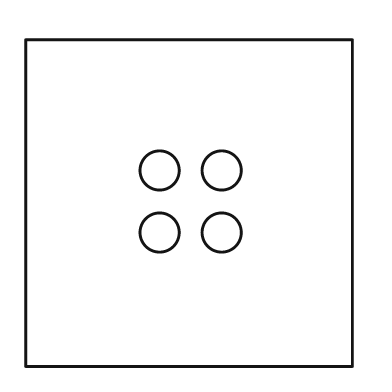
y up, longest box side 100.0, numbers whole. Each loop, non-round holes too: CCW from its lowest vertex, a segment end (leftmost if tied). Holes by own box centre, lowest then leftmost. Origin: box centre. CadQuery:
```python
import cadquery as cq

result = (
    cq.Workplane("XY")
    .moveTo(-50.0, -50.0)
    .lineTo(50.0, -50.0)
    .lineTo(50.0, 50.0)
    .lineTo(-50.0, 50.0)
    .close()
    .moveTo(-9.0, -9.0)
    .circle(6.0)
    .moveTo(10.0, -9.0)
    .circle(6.0)
    .moveTo(-9.0, 10.0)
    .circle(6.0)
    .moveTo(10.0, 10.0)
    .circle(6.0)
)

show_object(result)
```